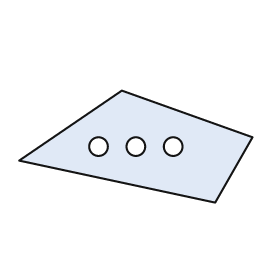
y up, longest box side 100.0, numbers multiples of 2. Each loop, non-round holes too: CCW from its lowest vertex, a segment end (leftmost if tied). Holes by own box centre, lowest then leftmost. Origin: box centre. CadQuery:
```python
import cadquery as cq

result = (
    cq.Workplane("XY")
    .moveTo(34.0, -24.0)
    .lineTo(50.0, 4.0)
    .lineTo(-6.0, 24.0)
    .lineTo(-50.0, -6.0)
    .close()
    .moveTo(-16.0, 0.0)
    .circle(4.0)
    .moveTo(0.0, 0.0)
    .circle(4.0)
    .moveTo(16.0, 0.0)
    .circle(4.0)
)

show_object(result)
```